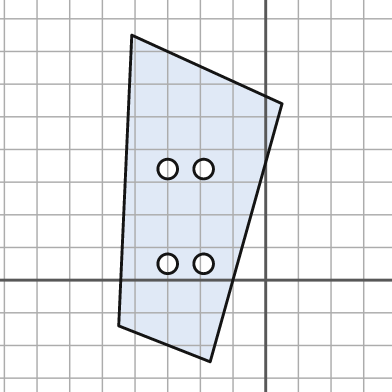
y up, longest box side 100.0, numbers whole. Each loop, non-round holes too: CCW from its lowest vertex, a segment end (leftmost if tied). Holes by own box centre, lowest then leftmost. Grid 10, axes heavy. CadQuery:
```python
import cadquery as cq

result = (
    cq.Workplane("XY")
    .moveTo(-17.0, -25.0)
    .lineTo(5.0, 54.0)
    .lineTo(-41.0, 75.0)
    .lineTo(-45.0, -14.0)
    .close()
    .moveTo(-30.0, 5.0)
    .circle(3.0)
    .moveTo(-19.0, 5.0)
    .circle(3.0)
    .moveTo(-30.0, 34.0)
    .circle(3.0)
    .moveTo(-19.0, 34.0)
    .circle(3.0)
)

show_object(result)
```